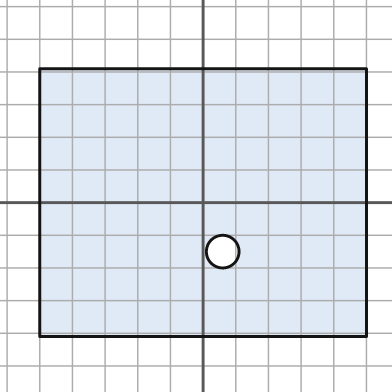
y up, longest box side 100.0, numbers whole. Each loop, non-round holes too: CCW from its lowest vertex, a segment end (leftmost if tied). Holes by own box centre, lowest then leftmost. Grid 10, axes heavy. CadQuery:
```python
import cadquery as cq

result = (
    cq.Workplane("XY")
    .moveTo(-50.0, -41.0)
    .lineTo(50.0, -41.0)
    .lineTo(50.0, 41.0)
    .lineTo(-50.0, 41.0)
    .close()
    .moveTo(6.0, -15.0)
    .circle(5.0)
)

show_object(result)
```